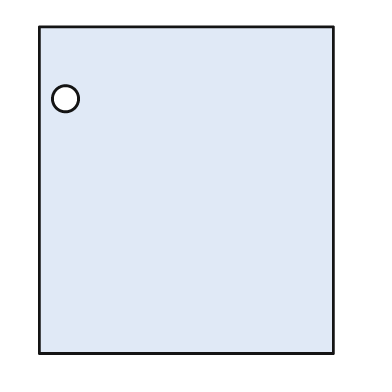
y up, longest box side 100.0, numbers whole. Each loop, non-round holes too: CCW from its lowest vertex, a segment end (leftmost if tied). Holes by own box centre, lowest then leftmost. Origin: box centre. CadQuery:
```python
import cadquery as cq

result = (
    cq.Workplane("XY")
    .moveTo(-45.0, -50.0)
    .lineTo(45.0, -50.0)
    .lineTo(45.0, 50.0)
    .lineTo(-45.0, 50.0)
    .close()
    .moveTo(-37.0, 28.0)
    .circle(4.0)
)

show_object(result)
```